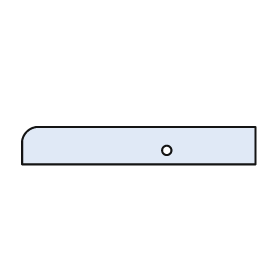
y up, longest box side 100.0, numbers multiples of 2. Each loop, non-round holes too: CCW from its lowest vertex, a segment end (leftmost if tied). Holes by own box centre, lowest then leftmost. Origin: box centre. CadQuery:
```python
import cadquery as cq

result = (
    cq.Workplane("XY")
    .moveTo(-50.0, -8.0)
    .lineTo(50.0, -8.0)
    .lineTo(50.0, 8.0)
    .lineTo(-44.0, 8.0)
    .threePointArc((-48.0, 6.0), (-50.0, 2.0))
    .close()
    .moveTo(12.0, -2.0)
    .circle(2.0)
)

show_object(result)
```